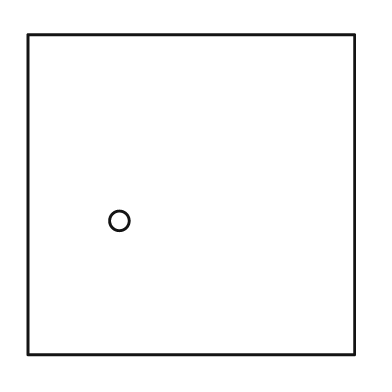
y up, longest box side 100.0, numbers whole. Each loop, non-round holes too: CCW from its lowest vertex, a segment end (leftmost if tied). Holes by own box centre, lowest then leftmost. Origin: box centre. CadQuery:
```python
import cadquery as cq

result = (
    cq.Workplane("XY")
    .moveTo(-50.0, -49.0)
    .lineTo(50.0, -49.0)
    .lineTo(50.0, 49.0)
    .lineTo(-50.0, 49.0)
    .close()
    .moveTo(-22.0, -8.0)
    .circle(3.0)
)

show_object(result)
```